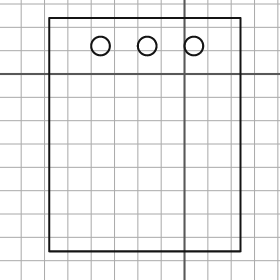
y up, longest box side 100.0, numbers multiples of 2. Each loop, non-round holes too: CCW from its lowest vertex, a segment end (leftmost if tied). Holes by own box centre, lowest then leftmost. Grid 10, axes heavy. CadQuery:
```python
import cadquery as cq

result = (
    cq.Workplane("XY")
    .moveTo(-58.0, -76.0)
    .lineTo(24.0, -76.0)
    .lineTo(24.0, 24.0)
    .lineTo(-58.0, 24.0)
    .close()
    .moveTo(-36.0, 12.0)
    .circle(4.0)
    .moveTo(-16.0, 12.0)
    .circle(4.0)
    .moveTo(4.0, 12.0)
    .circle(4.0)
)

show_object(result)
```